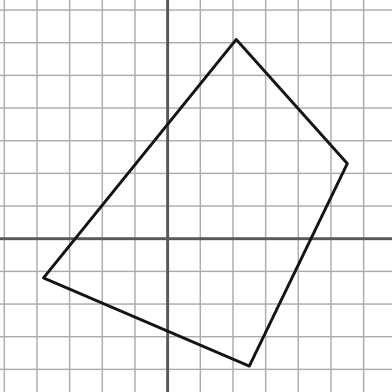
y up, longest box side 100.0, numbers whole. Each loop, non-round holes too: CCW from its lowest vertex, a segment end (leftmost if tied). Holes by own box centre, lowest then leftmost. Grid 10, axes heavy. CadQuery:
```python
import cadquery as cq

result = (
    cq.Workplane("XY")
    .moveTo(25.0, -39.0)
    .lineTo(55.0, 23.0)
    .lineTo(21.0, 61.0)
    .lineTo(-38.0, -12.0)
    .close()
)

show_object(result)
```